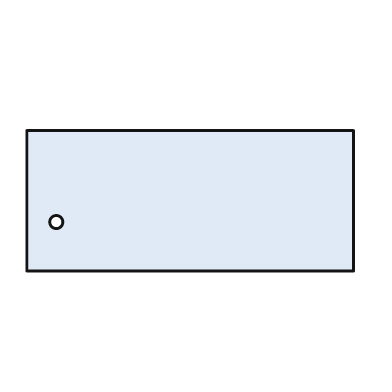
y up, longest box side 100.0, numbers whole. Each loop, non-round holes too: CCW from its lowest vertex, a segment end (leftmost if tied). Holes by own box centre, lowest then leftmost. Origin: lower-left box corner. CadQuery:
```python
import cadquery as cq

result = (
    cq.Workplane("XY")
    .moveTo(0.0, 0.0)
    .lineTo(100.0, 0.0)
    .lineTo(100.0, 43.0)
    .lineTo(0.0, 43.0)
    .close()
    .moveTo(9.0, 15.0)
    .circle(2.0)
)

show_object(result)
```